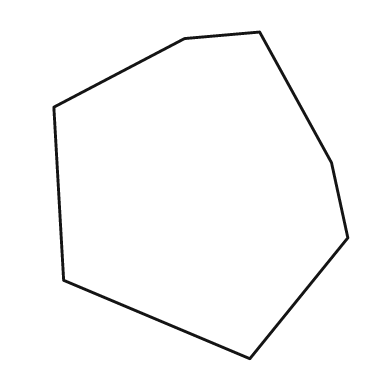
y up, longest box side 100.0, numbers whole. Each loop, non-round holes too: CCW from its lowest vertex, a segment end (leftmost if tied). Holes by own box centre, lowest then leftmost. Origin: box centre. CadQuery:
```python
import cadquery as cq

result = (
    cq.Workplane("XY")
    .moveTo(15.0, -50.0)
    .lineTo(45.0, -13.0)
    .lineTo(40.0, 10.0)
    .lineTo(18.0, 50.0)
    .lineTo(-5.0, 48.0)
    .lineTo(-45.0, 27.0)
    .lineTo(-42.0, -26.0)
    .close()
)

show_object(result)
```